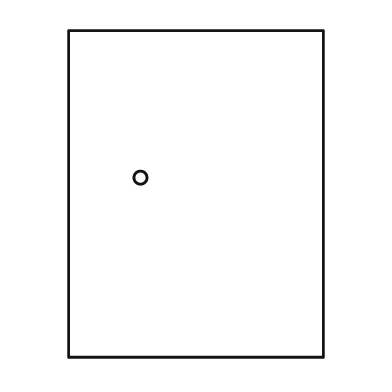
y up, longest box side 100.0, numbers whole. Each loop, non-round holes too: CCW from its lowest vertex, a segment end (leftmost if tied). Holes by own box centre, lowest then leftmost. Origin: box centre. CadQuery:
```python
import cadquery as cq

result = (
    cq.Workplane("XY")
    .moveTo(-39.0, -50.0)
    .lineTo(39.0, -50.0)
    .lineTo(39.0, 50.0)
    .lineTo(-39.0, 50.0)
    .close()
    .moveTo(-17.0, 5.0)
    .circle(2.0)
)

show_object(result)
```